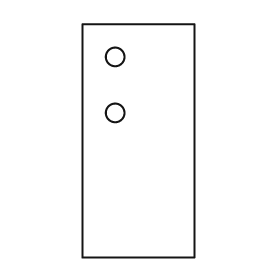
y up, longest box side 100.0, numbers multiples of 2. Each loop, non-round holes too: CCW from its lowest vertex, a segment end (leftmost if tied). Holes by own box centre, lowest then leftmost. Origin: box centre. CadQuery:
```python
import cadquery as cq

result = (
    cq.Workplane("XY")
    .moveTo(-24.0, -50.0)
    .lineTo(24.0, -50.0)
    .lineTo(24.0, 50.0)
    .lineTo(-24.0, 50.0)
    .close()
    .moveTo(-10.0, 12.0)
    .circle(4.0)
    .moveTo(-10.0, 36.0)
    .circle(4.0)
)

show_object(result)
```